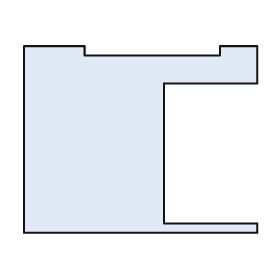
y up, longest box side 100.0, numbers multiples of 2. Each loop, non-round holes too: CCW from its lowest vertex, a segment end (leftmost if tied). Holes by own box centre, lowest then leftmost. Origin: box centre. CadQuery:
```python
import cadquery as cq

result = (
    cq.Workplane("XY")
    .moveTo(-50.0, -40.0)
    .lineTo(50.0, -40.0)
    .lineTo(50.0, -36.0)
    .lineTo(10.0, -36.0)
    .lineTo(10.0, 24.0)
    .lineTo(50.0, 24.0)
    .lineTo(50.0, 40.0)
    .lineTo(34.0, 40.0)
    .lineTo(34.0, 36.0)
    .lineTo(-24.0, 36.0)
    .lineTo(-24.0, 40.0)
    .lineTo(-50.0, 40.0)
    .close()
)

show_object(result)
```